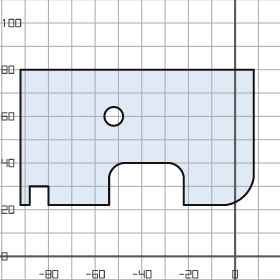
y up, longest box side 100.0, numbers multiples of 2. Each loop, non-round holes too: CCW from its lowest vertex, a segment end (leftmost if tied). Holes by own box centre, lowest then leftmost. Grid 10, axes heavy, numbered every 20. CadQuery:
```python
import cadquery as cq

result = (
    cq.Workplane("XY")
    .moveTo(-92.0, 22.0)
    .lineTo(-88.0, 22.0)
    .lineTo(-88.0, 30.0)
    .lineTo(-80.0, 30.0)
    .lineTo(-80.0, 22.0)
    .lineTo(-54.0, 22.0)
    .lineTo(-54.0, 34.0)
    .threePointArc((-52.0, 38.0), (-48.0, 40.0))
    .lineTo(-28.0, 40.0)
    .threePointArc((-24.0, 38.0), (-22.0, 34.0))
    .lineTo(-22.0, 22.0)
    .lineTo(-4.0, 22.0)
    .threePointArc((4.0, 26.0), (8.0, 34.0))
    .lineTo(8.0, 80.0)
    .lineTo(-92.0, 80.0)
    .close()
    .moveTo(-52.0, 60.0)
    .circle(4.0)
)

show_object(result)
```